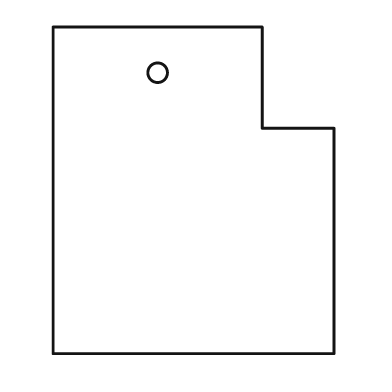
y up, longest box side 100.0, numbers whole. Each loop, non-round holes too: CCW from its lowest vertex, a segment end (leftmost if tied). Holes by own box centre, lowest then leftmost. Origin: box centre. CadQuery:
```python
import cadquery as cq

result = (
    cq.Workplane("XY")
    .moveTo(-43.0, -50.0)
    .lineTo(43.0, -50.0)
    .lineTo(43.0, 19.0)
    .lineTo(21.0, 19.0)
    .lineTo(21.0, 50.0)
    .lineTo(-43.0, 50.0)
    .close()
    .moveTo(-11.0, 36.0)
    .circle(3.0)
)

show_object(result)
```